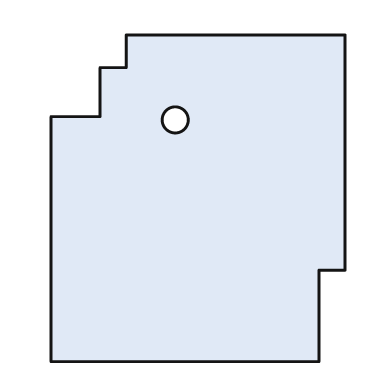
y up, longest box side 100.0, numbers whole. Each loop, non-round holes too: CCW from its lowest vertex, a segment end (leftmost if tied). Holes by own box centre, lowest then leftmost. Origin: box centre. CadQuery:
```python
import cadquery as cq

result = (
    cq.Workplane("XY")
    .moveTo(-45.0, -50.0)
    .lineTo(37.0, -50.0)
    .lineTo(37.0, -22.0)
    .lineTo(45.0, -22.0)
    .lineTo(45.0, 50.0)
    .lineTo(-22.0, 50.0)
    .lineTo(-22.0, 40.0)
    .lineTo(-30.0, 40.0)
    .lineTo(-30.0, 25.0)
    .lineTo(-45.0, 25.0)
    .close()
    .moveTo(-7.0, 24.0)
    .circle(4.0)
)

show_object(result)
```